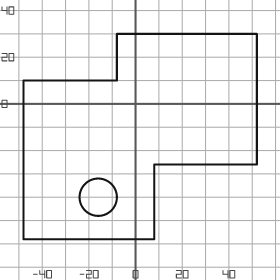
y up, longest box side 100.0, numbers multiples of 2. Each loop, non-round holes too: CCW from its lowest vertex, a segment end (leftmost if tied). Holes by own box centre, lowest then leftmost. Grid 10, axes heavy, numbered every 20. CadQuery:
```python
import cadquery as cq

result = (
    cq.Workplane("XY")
    .moveTo(-48.0, -58.0)
    .lineTo(8.0, -58.0)
    .lineTo(8.0, -26.0)
    .lineTo(52.0, -26.0)
    .lineTo(52.0, 30.0)
    .lineTo(-8.0, 30.0)
    .lineTo(-8.0, 10.0)
    .lineTo(-48.0, 10.0)
    .close()
    .moveTo(-16.0, -40.0)
    .circle(8.0)
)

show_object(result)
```